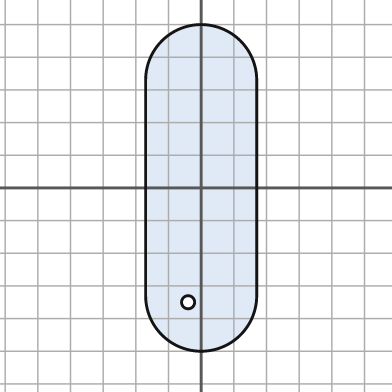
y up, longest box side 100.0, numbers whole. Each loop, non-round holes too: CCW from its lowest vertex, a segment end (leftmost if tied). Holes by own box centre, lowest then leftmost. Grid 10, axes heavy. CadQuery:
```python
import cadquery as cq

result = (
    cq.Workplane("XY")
    .moveTo(-17.0, -33.0)
    .threePointArc((0.0, -50.0), (17.0, -33.0))
    .lineTo(17.0, 33.0)
    .threePointArc((0.0, 50.0), (-17.0, 33.0))
    .close()
    .moveTo(-4.0, -35.0)
    .circle(2.0)
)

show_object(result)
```